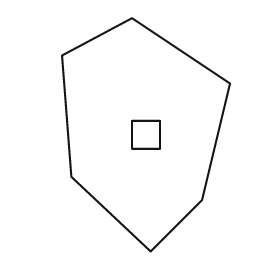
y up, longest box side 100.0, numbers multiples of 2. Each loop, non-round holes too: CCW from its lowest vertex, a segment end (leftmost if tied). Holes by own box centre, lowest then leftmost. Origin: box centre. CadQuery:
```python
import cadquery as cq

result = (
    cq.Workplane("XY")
    .moveTo(2.0, -50.0)
    .lineTo(24.0, -28.0)
    .lineTo(36.0, 22.0)
    .lineTo(-6.0, 50.0)
    .lineTo(-36.0, 34.0)
    .lineTo(-32.0, -18.0)
    .close()
    .moveTo(-6.0, -6.0)
    .lineTo(6.0, -6.0)
    .lineTo(6.0, 6.0)
    .lineTo(-6.0, 6.0)
    .close()
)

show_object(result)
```